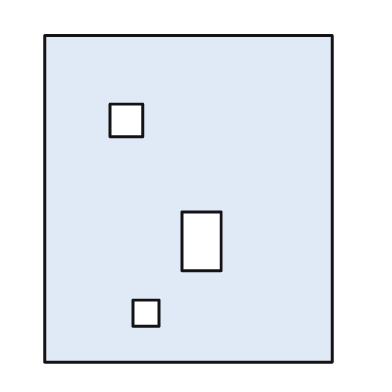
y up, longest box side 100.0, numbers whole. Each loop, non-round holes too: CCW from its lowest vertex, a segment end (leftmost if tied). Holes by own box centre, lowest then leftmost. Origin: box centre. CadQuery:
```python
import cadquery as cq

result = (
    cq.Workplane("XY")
    .moveTo(-44.0, -50.0)
    .lineTo(44.0, -50.0)
    .lineTo(44.0, 50.0)
    .lineTo(-44.0, 50.0)
    .close()
    .moveTo(-17.0, -39.0)
    .lineTo(-9.0, -39.0)
    .lineTo(-9.0, -31.0)
    .lineTo(-17.0, -31.0)
    .close()
    .moveTo(-2.0, -22.0)
    .lineTo(10.0, -22.0)
    .lineTo(10.0, -4.0)
    .lineTo(-2.0, -4.0)
    .close()
    .moveTo(-24.0, 19.0)
    .lineTo(-14.0, 19.0)
    .lineTo(-14.0, 29.0)
    .lineTo(-24.0, 29.0)
    .close()
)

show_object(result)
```